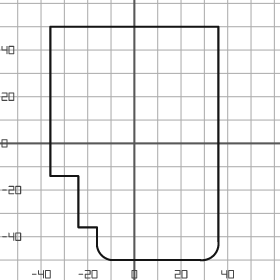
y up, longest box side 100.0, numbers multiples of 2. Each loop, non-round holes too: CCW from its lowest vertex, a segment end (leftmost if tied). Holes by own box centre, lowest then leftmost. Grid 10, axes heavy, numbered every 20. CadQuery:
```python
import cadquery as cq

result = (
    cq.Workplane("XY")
    .moveTo(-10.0, -50.0)
    .lineTo(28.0, -50.0)
    .threePointArc((34.0, -48.0), (36.0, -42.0))
    .lineTo(36.0, 50.0)
    .lineTo(-36.0, 50.0)
    .lineTo(-36.0, -14.0)
    .lineTo(-24.0, -14.0)
    .lineTo(-24.0, -36.0)
    .lineTo(-16.0, -36.0)
    .lineTo(-16.0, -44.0)
    .threePointArc((-14.0, -48.0), (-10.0, -50.0))
    .close()
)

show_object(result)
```